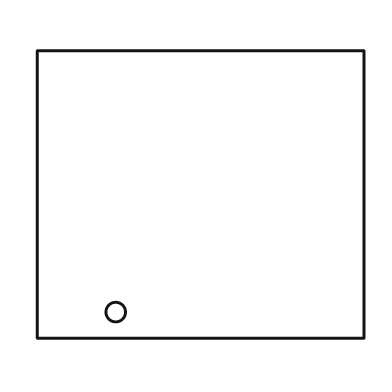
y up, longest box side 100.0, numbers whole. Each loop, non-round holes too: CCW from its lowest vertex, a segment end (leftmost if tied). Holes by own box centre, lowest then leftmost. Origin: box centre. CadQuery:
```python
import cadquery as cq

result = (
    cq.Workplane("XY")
    .moveTo(-50.0, -44.0)
    .lineTo(50.0, -44.0)
    .lineTo(50.0, 44.0)
    .lineTo(-50.0, 44.0)
    .close()
    .moveTo(-26.0, -36.0)
    .circle(3.0)
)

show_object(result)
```